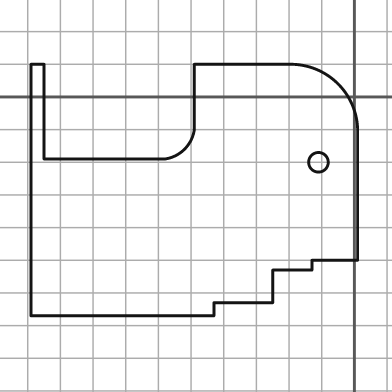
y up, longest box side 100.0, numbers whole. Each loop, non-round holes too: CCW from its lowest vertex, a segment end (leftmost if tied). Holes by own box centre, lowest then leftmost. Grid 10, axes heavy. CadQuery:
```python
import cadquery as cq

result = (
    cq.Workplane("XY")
    .moveTo(-99.0, -67.0)
    .lineTo(-43.0, -67.0)
    .lineTo(-43.0, -63.0)
    .lineTo(-25.0, -63.0)
    .lineTo(-25.0, -53.0)
    .lineTo(-13.0, -53.0)
    .lineTo(-13.0, -50.0)
    .lineTo(1.0, -50.0)
    .lineTo(1.0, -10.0)
    .threePointArc((-5.0, 4.0), (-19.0, 10.0))
    .lineTo(-49.0, 10.0)
    .lineTo(-49.0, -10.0)
    .threePointArc((-52.0, -16.0), (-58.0, -19.0))
    .lineTo(-95.0, -19.0)
    .lineTo(-95.0, 10.0)
    .lineTo(-99.0, 10.0)
    .close()
    .moveTo(-11.0, -20.0)
    .circle(3.0)
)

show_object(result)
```